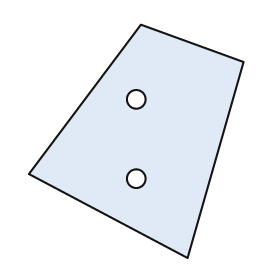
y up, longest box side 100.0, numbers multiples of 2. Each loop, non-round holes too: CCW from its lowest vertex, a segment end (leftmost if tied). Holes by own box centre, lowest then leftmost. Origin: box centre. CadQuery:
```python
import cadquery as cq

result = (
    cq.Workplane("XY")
    .moveTo(22.0, -50.0)
    .lineTo(46.0, 34.0)
    .lineTo(2.0, 50.0)
    .lineTo(-46.0, -14.0)
    .close()
    .moveTo(0.0, -16.0)
    .circle(4.0)
    .moveTo(0.0, 18.0)
    .circle(4.0)
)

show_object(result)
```